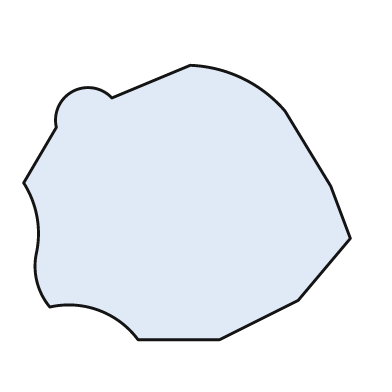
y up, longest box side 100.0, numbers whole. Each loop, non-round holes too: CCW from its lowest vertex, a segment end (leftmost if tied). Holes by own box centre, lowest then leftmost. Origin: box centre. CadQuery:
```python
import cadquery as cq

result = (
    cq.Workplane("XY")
    .moveTo(-15.0, -42.0)
    .lineTo(10.0, -42.0)
    .lineTo(34.0, -30.0)
    .lineTo(50.0, -11.0)
    .lineTo(44.0, 5.0)
    .lineTo(30.0, 28.0)
    .threePointArc((17.0, 38.0), (1.0, 42.0))
    .lineTo(-23.0, 32.0)
    .threePointArc((-35.0, 34.0), (-40.0, 23.0))
    .lineTo(-50.0, 6.0)
    .threePointArc((-46.0, -4.0), (-46.0, -15.0))
    .threePointArc((-46.0, -24.0), (-42.0, -32.0))
    .threePointArc((-27.0, -33.0), (-15.0, -42.0))
    .close()
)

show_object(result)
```